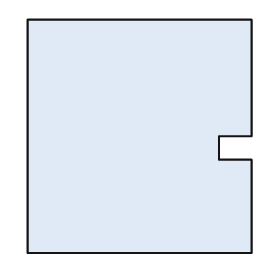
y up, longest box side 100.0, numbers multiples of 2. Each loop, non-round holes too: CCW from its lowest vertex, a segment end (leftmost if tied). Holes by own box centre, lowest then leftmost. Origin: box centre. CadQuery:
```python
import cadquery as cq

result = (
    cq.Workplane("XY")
    .moveTo(-48.0, -50.0)
    .lineTo(48.0, -50.0)
    .lineTo(48.0, -10.0)
    .lineTo(34.0, -10.0)
    .lineTo(34.0, 0.0)
    .lineTo(48.0, 0.0)
    .lineTo(48.0, 50.0)
    .lineTo(-48.0, 50.0)
    .close()
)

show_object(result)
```